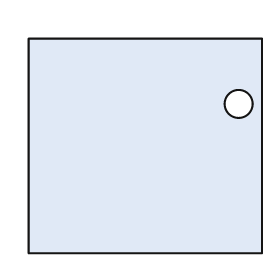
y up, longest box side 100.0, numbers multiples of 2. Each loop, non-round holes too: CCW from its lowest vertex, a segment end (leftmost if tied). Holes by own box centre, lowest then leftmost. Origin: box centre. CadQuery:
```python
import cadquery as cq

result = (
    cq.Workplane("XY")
    .moveTo(-50.0, -46.0)
    .lineTo(50.0, -46.0)
    .lineTo(50.0, 46.0)
    .lineTo(-50.0, 46.0)
    .close()
    .moveTo(40.0, 18.0)
    .circle(6.0)
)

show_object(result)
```